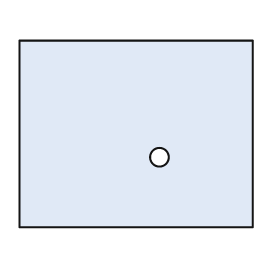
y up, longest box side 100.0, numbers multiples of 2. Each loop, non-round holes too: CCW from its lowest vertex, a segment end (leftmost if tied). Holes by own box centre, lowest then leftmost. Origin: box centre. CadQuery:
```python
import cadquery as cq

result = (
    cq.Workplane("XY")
    .moveTo(-50.0, -40.0)
    .lineTo(50.0, -40.0)
    .lineTo(50.0, 40.0)
    .lineTo(-50.0, 40.0)
    .close()
    .moveTo(10.0, -10.0)
    .circle(4.0)
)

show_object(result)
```